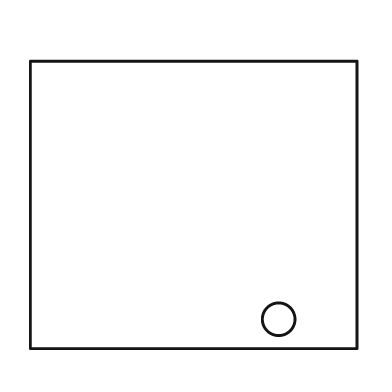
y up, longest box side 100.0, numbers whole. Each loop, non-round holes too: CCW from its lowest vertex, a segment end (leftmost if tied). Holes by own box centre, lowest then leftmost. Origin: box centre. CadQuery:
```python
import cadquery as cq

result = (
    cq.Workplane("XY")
    .moveTo(-50.0, -44.0)
    .lineTo(50.0, -44.0)
    .lineTo(50.0, 44.0)
    .lineTo(-50.0, 44.0)
    .close()
    .moveTo(26.0, -35.0)
    .circle(5.0)
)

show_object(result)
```